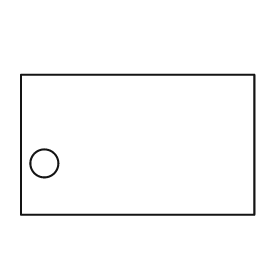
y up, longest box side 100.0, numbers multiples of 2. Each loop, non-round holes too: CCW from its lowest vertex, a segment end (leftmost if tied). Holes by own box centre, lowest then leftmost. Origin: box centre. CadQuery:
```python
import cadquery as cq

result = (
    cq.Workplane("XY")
    .moveTo(-50.0, -30.0)
    .lineTo(50.0, -30.0)
    .lineTo(50.0, 30.0)
    .lineTo(-50.0, 30.0)
    .close()
    .moveTo(-40.0, -8.0)
    .circle(6.0)
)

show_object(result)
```